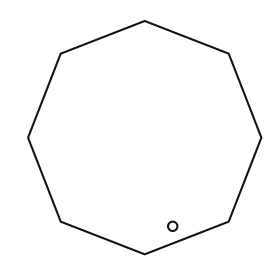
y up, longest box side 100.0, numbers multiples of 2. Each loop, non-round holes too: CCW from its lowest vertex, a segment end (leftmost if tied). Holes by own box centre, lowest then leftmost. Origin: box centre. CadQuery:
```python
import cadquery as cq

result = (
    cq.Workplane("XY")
    .moveTo(0.0, -50.0)
    .lineTo(36.0, -36.0)
    .lineTo(50.0, 0.0)
    .lineTo(36.0, 36.0)
    .lineTo(0.0, 50.0)
    .lineTo(-36.0, 36.0)
    .lineTo(-50.0, 0.0)
    .lineTo(-36.0, -36.0)
    .close()
    .moveTo(12.0, -38.0)
    .circle(2.0)
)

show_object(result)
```